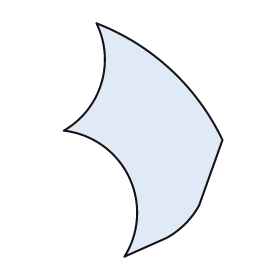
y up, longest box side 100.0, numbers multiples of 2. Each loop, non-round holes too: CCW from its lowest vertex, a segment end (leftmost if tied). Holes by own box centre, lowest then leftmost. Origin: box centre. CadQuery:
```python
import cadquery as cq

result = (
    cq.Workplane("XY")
    .moveTo(-8.0, -50.0)
    .lineTo(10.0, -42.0)
    .threePointArc((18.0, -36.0), (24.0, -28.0))
    .lineTo(34.0, 0.0)
    .threePointArc((12.0, 30.0), (-20.0, 50.0))
    .threePointArc((-18.0, 24.0), (-34.0, 4.0))
    .threePointArc((-6.0, -16.0), (-8.0, -50.0))
    .close()
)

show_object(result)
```